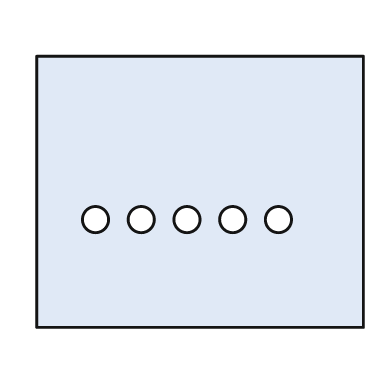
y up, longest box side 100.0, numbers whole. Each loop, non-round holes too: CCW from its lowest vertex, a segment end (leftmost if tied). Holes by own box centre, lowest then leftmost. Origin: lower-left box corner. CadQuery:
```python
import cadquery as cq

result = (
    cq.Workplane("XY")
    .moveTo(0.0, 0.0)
    .lineTo(100.0, 0.0)
    .lineTo(100.0, 83.0)
    .lineTo(0.0, 83.0)
    .close()
    .moveTo(18.0, 33.0)
    .circle(4.0)
    .moveTo(32.0, 33.0)
    .circle(4.0)
    .moveTo(46.0, 33.0)
    .circle(4.0)
    .moveTo(60.0, 33.0)
    .circle(4.0)
    .moveTo(74.0, 33.0)
    .circle(4.0)
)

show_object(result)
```